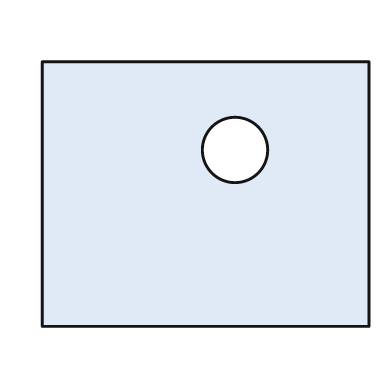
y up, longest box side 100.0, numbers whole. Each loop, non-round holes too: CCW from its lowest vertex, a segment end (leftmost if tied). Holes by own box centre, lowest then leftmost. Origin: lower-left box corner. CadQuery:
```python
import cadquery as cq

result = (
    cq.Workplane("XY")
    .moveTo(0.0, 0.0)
    .lineTo(100.0, 0.0)
    .lineTo(100.0, 81.0)
    .lineTo(0.0, 81.0)
    .close()
    .moveTo(59.0, 54.0)
    .circle(10.0)
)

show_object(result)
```